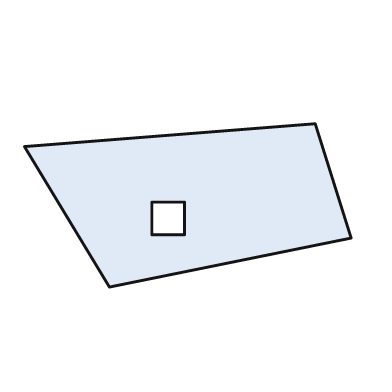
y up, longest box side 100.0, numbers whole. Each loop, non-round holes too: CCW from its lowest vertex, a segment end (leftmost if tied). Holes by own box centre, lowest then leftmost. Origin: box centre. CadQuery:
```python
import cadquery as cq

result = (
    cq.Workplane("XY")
    .moveTo(-24.0, -25.0)
    .lineTo(50.0, -10.0)
    .lineTo(39.0, 25.0)
    .lineTo(-50.0, 18.0)
    .close()
    .moveTo(-11.0, -9.0)
    .lineTo(-1.0, -9.0)
    .lineTo(-1.0, 1.0)
    .lineTo(-11.0, 1.0)
    .close()
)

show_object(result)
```